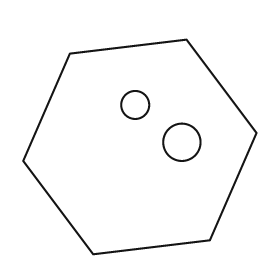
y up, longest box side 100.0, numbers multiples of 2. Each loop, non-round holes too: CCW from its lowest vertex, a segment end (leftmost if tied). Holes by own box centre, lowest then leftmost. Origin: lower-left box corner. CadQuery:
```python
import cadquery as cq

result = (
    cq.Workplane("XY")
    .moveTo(30.0, 0.0)
    .lineTo(80.0, 6.0)
    .lineTo(100.0, 52.0)
    .lineTo(70.0, 92.0)
    .lineTo(20.0, 86.0)
    .lineTo(0.0, 40.0)
    .close()
    .moveTo(68.0, 48.0)
    .circle(8.0)
    .moveTo(48.0, 64.0)
    .circle(6.0)
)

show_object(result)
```